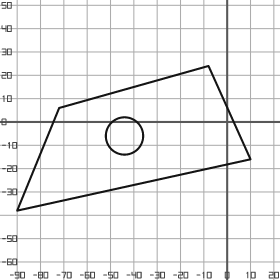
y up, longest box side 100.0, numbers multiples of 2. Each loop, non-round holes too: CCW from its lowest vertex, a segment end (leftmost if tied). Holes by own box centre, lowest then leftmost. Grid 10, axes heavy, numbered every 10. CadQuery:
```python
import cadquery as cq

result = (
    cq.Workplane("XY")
    .moveTo(-90.0, -38.0)
    .lineTo(10.0, -16.0)
    .lineTo(-8.0, 24.0)
    .lineTo(-72.0, 6.0)
    .close()
    .moveTo(-44.0, -6.0)
    .circle(8.0)
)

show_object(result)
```